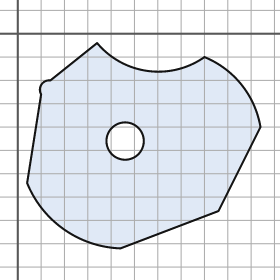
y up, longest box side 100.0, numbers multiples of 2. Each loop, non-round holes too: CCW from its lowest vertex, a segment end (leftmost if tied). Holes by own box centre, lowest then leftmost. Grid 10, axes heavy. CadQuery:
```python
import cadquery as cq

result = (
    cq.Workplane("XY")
    .moveTo(44.0, -92.0)
    .lineTo(86.0, -76.0)
    .lineTo(104.0, -40.0)
    .threePointArc((96.0, -22.0), (80.0, -10.0))
    .threePointArc((56.0, -16.0), (34.0, -4.0))
    .lineTo(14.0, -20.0)
    .threePointArc((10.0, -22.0), (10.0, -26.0))
    .lineTo(4.0, -64.0)
    .threePointArc((20.0, -84.0), (44.0, -92.0))
    .close()
    .moveTo(46.0, -46.0)
    .circle(8.0)
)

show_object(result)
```